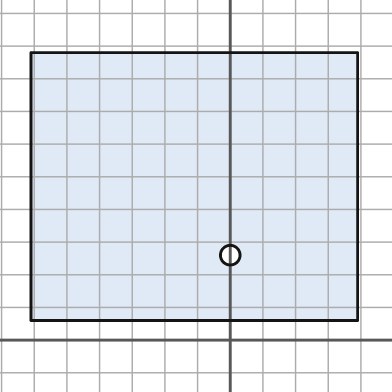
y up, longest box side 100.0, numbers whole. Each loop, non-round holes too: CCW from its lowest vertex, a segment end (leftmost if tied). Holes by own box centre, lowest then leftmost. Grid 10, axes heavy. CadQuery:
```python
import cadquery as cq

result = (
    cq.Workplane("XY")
    .moveTo(-61.0, 6.0)
    .lineTo(39.0, 6.0)
    .lineTo(39.0, 88.0)
    .lineTo(-61.0, 88.0)
    .close()
    .moveTo(0.0, 26.0)
    .circle(3.0)
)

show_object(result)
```